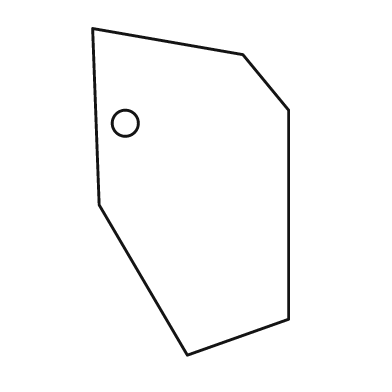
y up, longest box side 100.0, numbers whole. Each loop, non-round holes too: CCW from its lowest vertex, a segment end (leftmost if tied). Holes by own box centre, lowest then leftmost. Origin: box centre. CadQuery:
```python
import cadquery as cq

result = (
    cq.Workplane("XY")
    .moveTo(-1.0, -50.0)
    .lineTo(30.0, -39.0)
    .lineTo(30.0, 25.0)
    .lineTo(16.0, 42.0)
    .lineTo(-30.0, 50.0)
    .lineTo(-28.0, -4.0)
    .close()
    .moveTo(-20.0, 21.0)
    .circle(4.0)
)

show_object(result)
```